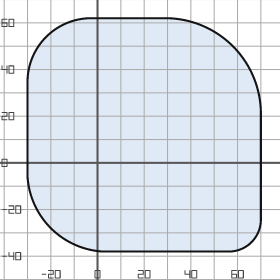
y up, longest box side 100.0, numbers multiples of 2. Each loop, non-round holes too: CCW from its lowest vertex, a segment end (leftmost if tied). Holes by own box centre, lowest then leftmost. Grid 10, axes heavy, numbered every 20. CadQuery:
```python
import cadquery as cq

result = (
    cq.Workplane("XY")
    .moveTo(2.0, -38.0)
    .lineTo(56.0, -38.0)
    .threePointArc((66.0, -34.0), (70.0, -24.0))
    .lineTo(70.0, 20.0)
    .threePointArc((58.0, 50.0), (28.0, 62.0))
    .lineTo(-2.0, 62.0)
    .threePointArc((-22.0, 54.0), (-30.0, 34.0))
    .lineTo(-30.0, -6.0)
    .threePointArc((-20.0, -28.0), (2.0, -38.0))
    .close()
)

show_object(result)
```